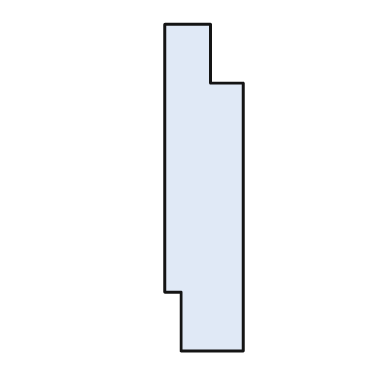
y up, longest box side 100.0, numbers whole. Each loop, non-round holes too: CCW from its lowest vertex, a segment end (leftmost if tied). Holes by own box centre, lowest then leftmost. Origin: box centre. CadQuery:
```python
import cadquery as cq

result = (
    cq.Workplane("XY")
    .moveTo(-7.0, -50.0)
    .lineTo(12.0, -50.0)
    .lineTo(12.0, 32.0)
    .lineTo(2.0, 32.0)
    .lineTo(2.0, 50.0)
    .lineTo(-12.0, 50.0)
    .lineTo(-12.0, -32.0)
    .lineTo(-7.0, -32.0)
    .close()
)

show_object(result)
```